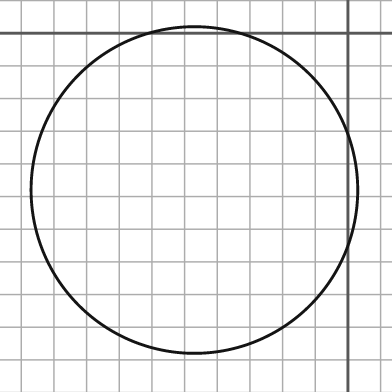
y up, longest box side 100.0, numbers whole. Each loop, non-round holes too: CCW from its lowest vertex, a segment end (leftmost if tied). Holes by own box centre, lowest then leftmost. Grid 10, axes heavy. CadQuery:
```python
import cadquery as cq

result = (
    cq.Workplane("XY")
    .moveTo(-47.0, -48.0)
    .circle(50.0)
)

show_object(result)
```